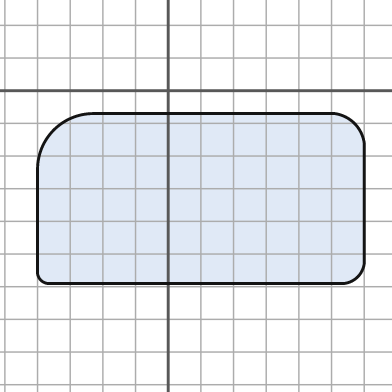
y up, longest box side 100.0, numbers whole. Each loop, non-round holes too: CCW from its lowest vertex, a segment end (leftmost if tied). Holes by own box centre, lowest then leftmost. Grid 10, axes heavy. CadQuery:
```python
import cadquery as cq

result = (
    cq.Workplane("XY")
    .moveTo(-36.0, -59.0)
    .lineTo(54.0, -59.0)
    .threePointArc((58.0, -57.0), (60.0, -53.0))
    .lineTo(60.0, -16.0)
    .threePointArc((57.0, -10.0), (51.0, -7.0))
    .lineTo(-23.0, -7.0)
    .threePointArc((-35.0, -12.0), (-40.0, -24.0))
    .lineTo(-40.0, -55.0)
    .threePointArc((-39.0, -58.0), (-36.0, -59.0))
    .close()
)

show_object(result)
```